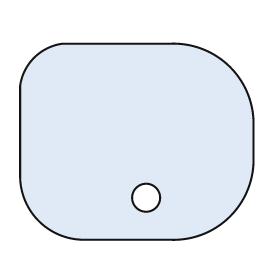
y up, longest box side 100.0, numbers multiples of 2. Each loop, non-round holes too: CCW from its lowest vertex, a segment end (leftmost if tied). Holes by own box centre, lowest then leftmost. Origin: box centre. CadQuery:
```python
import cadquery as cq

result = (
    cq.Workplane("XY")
    .moveTo(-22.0, -42.0)
    .lineTo(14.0, -42.0)
    .threePointArc((40.0, -32.0), (50.0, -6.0))
    .lineTo(50.0, 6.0)
    .threePointArc((40.0, 32.0), (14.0, 42.0))
    .lineTo(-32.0, 42.0)
    .threePointArc((-44.0, 36.0), (-50.0, 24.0))
    .lineTo(-50.0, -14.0)
    .threePointArc((-42.0, -34.0), (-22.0, -42.0))
    .close()
    .moveTo(4.0, -24.0)
    .circle(6.0)
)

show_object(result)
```